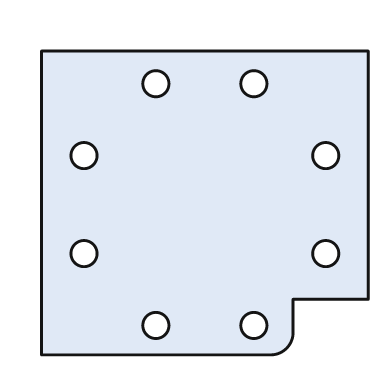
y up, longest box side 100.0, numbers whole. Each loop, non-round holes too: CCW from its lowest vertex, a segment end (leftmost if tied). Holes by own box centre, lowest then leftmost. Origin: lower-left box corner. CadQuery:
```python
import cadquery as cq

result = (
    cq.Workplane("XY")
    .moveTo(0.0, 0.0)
    .lineTo(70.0, 0.0)
    .threePointArc((75.0, 2.0), (77.0, 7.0))
    .lineTo(77.0, 17.0)
    .lineTo(100.0, 17.0)
    .lineTo(100.0, 93.0)
    .lineTo(0.0, 93.0)
    .close()
    .moveTo(35.0, 9.0)
    .circle(4.0)
    .moveTo(65.0, 9.0)
    .circle(4.0)
    .moveTo(13.0, 31.0)
    .circle(4.0)
    .moveTo(87.0, 31.0)
    .circle(4.0)
    .moveTo(13.0, 61.0)
    .circle(4.0)
    .moveTo(87.0, 61.0)
    .circle(4.0)
    .moveTo(35.0, 83.0)
    .circle(4.0)
    .moveTo(65.0, 83.0)
    .circle(4.0)
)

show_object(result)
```